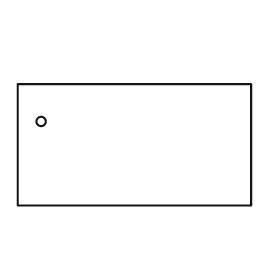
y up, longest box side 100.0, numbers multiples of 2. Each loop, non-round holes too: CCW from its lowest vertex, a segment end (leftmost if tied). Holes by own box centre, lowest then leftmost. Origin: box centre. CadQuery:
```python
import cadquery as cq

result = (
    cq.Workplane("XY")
    .moveTo(-50.0, -26.0)
    .lineTo(50.0, -26.0)
    .lineTo(50.0, 26.0)
    .lineTo(-50.0, 26.0)
    .close()
    .moveTo(-40.0, 10.0)
    .circle(2.0)
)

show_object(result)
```